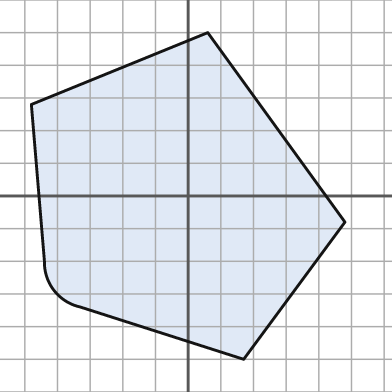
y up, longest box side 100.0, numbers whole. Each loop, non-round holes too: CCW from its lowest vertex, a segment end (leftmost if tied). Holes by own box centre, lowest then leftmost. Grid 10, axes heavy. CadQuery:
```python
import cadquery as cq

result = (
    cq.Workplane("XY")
    .moveTo(17.0, -50.0)
    .lineTo(48.0, -8.0)
    .lineTo(6.0, 50.0)
    .lineTo(-48.0, 28.0)
    .lineTo(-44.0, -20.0)
    .threePointArc((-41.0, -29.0), (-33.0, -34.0))
    .close()
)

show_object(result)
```